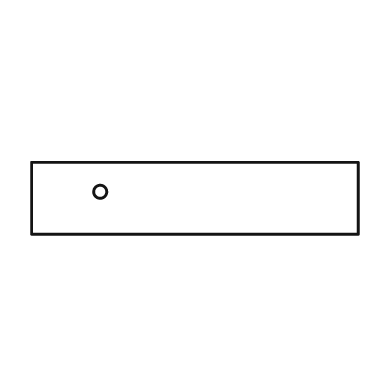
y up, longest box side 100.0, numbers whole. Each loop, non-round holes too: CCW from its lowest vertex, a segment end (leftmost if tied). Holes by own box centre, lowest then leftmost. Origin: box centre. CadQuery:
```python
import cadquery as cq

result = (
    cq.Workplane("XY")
    .moveTo(-50.0, -11.0)
    .lineTo(50.0, -11.0)
    .lineTo(50.0, 11.0)
    .lineTo(-50.0, 11.0)
    .close()
    .moveTo(-29.0, 2.0)
    .circle(2.0)
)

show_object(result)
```